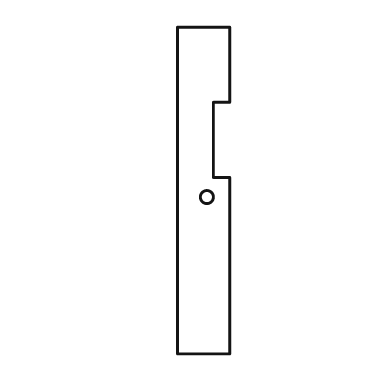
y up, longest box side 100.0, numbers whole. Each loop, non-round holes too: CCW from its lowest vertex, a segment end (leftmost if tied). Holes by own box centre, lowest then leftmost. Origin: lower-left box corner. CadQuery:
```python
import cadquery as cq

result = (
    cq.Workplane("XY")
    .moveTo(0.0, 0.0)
    .lineTo(16.0, 0.0)
    .lineTo(16.0, 54.0)
    .lineTo(11.0, 54.0)
    .lineTo(11.0, 77.0)
    .lineTo(16.0, 77.0)
    .lineTo(16.0, 100.0)
    .lineTo(0.0, 100.0)
    .close()
    .moveTo(9.0, 48.0)
    .circle(2.0)
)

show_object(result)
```